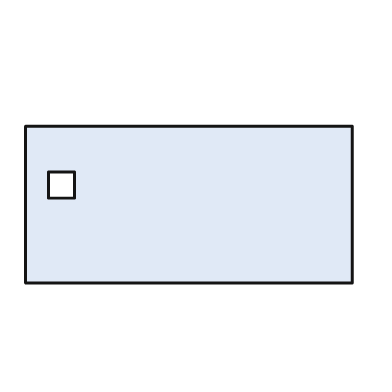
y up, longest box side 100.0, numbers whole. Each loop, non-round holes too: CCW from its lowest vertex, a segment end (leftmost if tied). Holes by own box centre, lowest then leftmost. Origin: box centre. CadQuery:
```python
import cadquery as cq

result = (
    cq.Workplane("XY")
    .moveTo(-50.0, -24.0)
    .lineTo(50.0, -24.0)
    .lineTo(50.0, 24.0)
    .lineTo(-50.0, 24.0)
    .close()
    .moveTo(-43.0, 2.0)
    .lineTo(-35.0, 2.0)
    .lineTo(-35.0, 10.0)
    .lineTo(-43.0, 10.0)
    .close()
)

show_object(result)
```